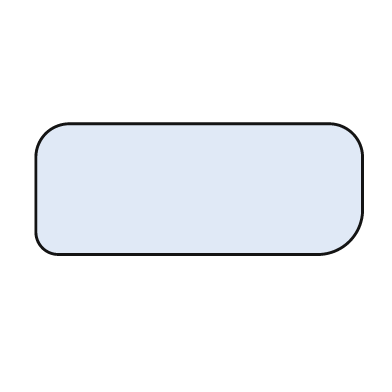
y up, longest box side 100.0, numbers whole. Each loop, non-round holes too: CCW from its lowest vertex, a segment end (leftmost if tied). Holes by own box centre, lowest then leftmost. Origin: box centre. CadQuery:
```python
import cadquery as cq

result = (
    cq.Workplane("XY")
    .moveTo(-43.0, -20.0)
    .lineTo(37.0, -20.0)
    .threePointArc((46.0, -16.0), (50.0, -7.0))
    .lineTo(50.0, 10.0)
    .threePointArc((47.0, 17.0), (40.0, 20.0))
    .lineTo(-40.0, 20.0)
    .threePointArc((-47.0, 17.0), (-50.0, 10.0))
    .lineTo(-50.0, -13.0)
    .threePointArc((-48.0, -18.0), (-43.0, -20.0))
    .close()
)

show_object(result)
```